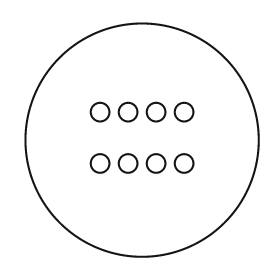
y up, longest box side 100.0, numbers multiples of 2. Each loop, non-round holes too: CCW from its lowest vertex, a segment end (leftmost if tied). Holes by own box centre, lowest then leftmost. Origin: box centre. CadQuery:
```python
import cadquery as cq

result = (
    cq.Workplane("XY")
    .moveTo(0.0, 0.0)
    .circle(50.0)
    .moveTo(-18.0, -10.0)
    .circle(4.0)
    .moveTo(-6.0, -10.0)
    .circle(4.0)
    .moveTo(6.0, -10.0)
    .circle(4.0)
    .moveTo(18.0, -10.0)
    .circle(4.0)
    .moveTo(-18.0, 12.0)
    .circle(4.0)
    .moveTo(-6.0, 12.0)
    .circle(4.0)
    .moveTo(6.0, 12.0)
    .circle(4.0)
    .moveTo(18.0, 12.0)
    .circle(4.0)
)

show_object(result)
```